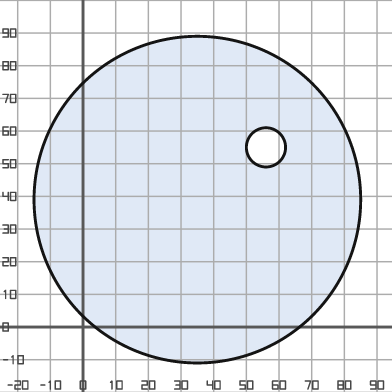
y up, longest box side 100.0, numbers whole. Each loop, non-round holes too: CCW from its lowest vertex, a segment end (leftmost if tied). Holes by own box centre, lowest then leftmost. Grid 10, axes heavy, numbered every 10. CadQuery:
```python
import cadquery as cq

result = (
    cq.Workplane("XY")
    .moveTo(35.0, 39.0)
    .circle(50.0)
    .moveTo(56.0, 55.0)
    .circle(6.0)
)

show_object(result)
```